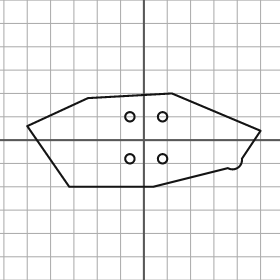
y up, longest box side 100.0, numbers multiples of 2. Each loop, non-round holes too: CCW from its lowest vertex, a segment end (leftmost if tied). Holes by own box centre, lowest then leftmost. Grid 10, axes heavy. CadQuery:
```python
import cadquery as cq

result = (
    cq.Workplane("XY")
    .moveTo(-32.0, -20.0)
    .lineTo(4.0, -20.0)
    .lineTo(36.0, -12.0)
    .threePointArc((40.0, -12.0), (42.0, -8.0))
    .lineTo(50.0, 4.0)
    .lineTo(12.0, 20.0)
    .lineTo(-24.0, 18.0)
    .lineTo(-50.0, 6.0)
    .close()
    .moveTo(-6.0, -8.0)
    .circle(2.0)
    .moveTo(8.0, -8.0)
    .circle(2.0)
    .moveTo(-6.0, 10.0)
    .circle(2.0)
    .moveTo(8.0, 10.0)
    .circle(2.0)
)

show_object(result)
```